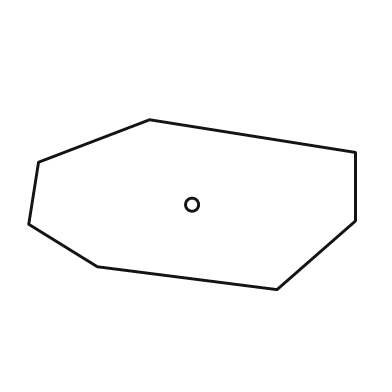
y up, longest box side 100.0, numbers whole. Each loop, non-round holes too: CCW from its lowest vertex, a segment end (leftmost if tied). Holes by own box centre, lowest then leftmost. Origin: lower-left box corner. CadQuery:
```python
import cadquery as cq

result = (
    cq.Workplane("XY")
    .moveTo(76.0, 0.0)
    .lineTo(100.0, 21.0)
    .lineTo(100.0, 42.0)
    .lineTo(37.0, 52.0)
    .lineTo(3.0, 39.0)
    .lineTo(0.0, 20.0)
    .lineTo(21.0, 7.0)
    .close()
    .moveTo(50.0, 26.0)
    .circle(2.0)
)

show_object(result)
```